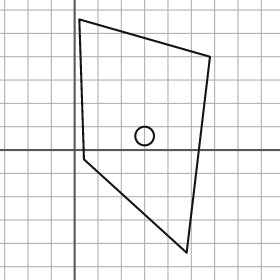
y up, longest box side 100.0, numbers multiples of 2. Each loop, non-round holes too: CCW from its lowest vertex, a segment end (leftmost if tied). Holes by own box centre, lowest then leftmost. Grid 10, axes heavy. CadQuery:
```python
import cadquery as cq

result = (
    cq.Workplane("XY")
    .moveTo(48.0, -44.0)
    .lineTo(58.0, 40.0)
    .lineTo(2.0, 56.0)
    .lineTo(4.0, -4.0)
    .close()
    .moveTo(30.0, 6.0)
    .circle(4.0)
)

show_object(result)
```